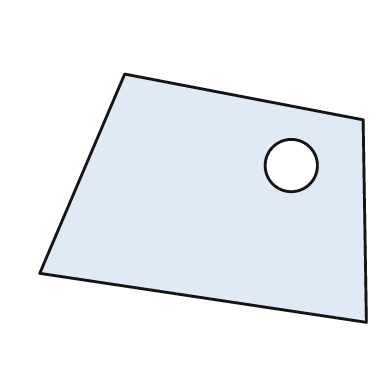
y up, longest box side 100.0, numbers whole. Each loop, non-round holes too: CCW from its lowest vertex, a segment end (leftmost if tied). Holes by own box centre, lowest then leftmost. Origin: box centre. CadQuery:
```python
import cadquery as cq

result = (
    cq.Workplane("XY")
    .moveTo(50.0, -38.0)
    .lineTo(49.0, 24.0)
    .lineTo(-24.0, 38.0)
    .lineTo(-50.0, -23.0)
    .close()
    .moveTo(27.0, 10.0)
    .circle(8.0)
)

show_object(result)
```